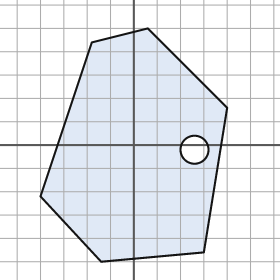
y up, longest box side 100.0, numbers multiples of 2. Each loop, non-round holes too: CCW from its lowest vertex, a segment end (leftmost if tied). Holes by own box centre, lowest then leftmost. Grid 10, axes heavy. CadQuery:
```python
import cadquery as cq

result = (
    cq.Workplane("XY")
    .moveTo(-14.0, -50.0)
    .lineTo(30.0, -46.0)
    .lineTo(40.0, 16.0)
    .lineTo(6.0, 50.0)
    .lineTo(-18.0, 44.0)
    .lineTo(-40.0, -22.0)
    .close()
    .moveTo(26.0, -2.0)
    .circle(6.0)
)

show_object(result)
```